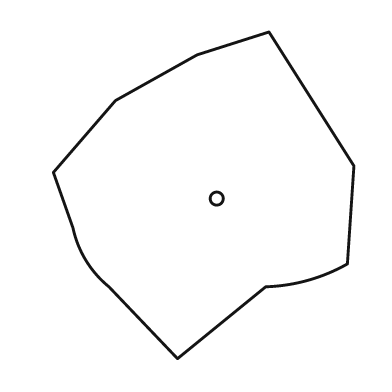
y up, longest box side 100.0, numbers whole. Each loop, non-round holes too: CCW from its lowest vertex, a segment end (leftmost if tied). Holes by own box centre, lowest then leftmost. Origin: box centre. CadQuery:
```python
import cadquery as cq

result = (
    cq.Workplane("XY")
    .moveTo(-8.0, -50.0)
    .lineTo(19.0, -28.0)
    .threePointArc((32.0, -26.0), (44.0, -21.0))
    .lineTo(46.0, 9.0)
    .lineTo(20.0, 50.0)
    .lineTo(-2.0, 43.0)
    .lineTo(-27.0, 29.0)
    .lineTo(-46.0, 7.0)
    .lineTo(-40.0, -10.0)
    .threePointArc((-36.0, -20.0), (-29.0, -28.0))
    .close()
    .moveTo(4.0, -1.0)
    .circle(2.0)
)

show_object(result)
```